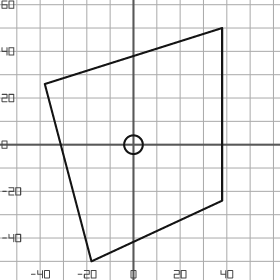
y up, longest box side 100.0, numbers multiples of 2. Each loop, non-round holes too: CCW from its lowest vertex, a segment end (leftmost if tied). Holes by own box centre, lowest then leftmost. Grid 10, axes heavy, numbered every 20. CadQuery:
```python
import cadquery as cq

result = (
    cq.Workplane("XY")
    .moveTo(-18.0, -50.0)
    .lineTo(38.0, -24.0)
    .lineTo(38.0, 50.0)
    .lineTo(-38.0, 26.0)
    .close()
    .moveTo(0.0, 0.0)
    .circle(4.0)
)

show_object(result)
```